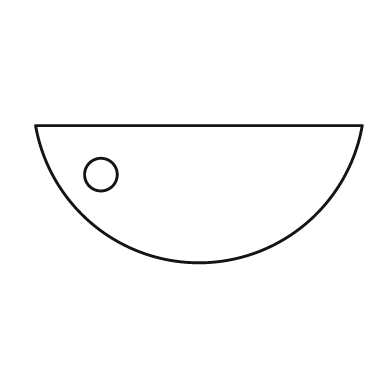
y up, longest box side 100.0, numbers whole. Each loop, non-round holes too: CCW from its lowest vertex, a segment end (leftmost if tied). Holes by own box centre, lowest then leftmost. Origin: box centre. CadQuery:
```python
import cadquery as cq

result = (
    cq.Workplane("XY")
    .moveTo(-50.0, 21.0)
    .threePointArc((0.0, -21.0), (50.0, 21.0))
    .close()
    .moveTo(-30.0, 6.0)
    .circle(5.0)
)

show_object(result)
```